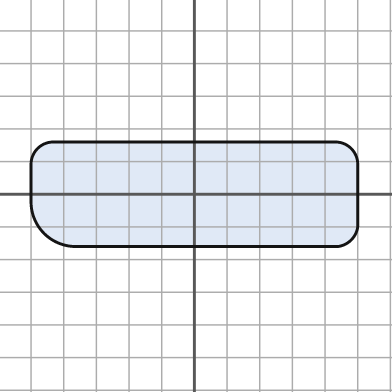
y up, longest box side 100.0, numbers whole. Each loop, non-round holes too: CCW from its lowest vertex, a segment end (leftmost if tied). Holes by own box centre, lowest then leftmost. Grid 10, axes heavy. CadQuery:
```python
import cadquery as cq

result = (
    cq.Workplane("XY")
    .moveTo(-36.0, -16.0)
    .lineTo(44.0, -16.0)
    .threePointArc((48.0, -14.0), (50.0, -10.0))
    .lineTo(50.0, 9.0)
    .threePointArc((48.0, 14.0), (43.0, 16.0))
    .lineTo(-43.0, 16.0)
    .threePointArc((-48.0, 14.0), (-50.0, 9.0))
    .lineTo(-50.0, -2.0)
    .threePointArc((-46.0, -12.0), (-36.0, -16.0))
    .close()
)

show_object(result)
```